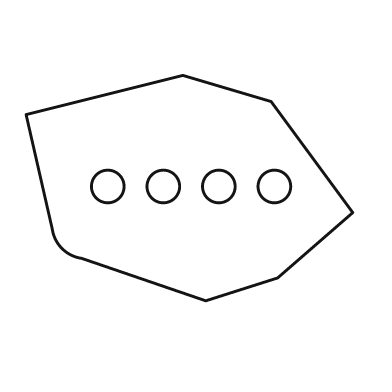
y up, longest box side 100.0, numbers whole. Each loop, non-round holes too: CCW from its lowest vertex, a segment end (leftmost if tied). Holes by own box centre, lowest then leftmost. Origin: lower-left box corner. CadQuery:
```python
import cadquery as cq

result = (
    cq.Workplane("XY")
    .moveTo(55.0, 0.0)
    .lineTo(77.0, 7.0)
    .lineTo(100.0, 27.0)
    .lineTo(75.0, 61.0)
    .lineTo(48.0, 69.0)
    .lineTo(0.0, 57.0)
    .lineTo(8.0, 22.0)
    .threePointArc((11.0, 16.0), (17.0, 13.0))
    .close()
    .moveTo(25.0, 35.0)
    .circle(5.0)
    .moveTo(42.0, 35.0)
    .circle(5.0)
    .moveTo(59.0, 35.0)
    .circle(5.0)
    .moveTo(76.0, 35.0)
    .circle(5.0)
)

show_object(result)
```